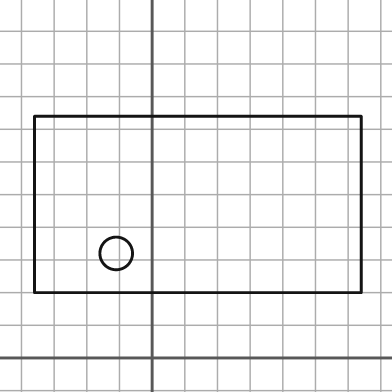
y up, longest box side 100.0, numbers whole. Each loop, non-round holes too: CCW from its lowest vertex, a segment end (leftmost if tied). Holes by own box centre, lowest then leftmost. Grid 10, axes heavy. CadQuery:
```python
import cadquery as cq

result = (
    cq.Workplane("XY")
    .moveTo(-36.0, 20.0)
    .lineTo(64.0, 20.0)
    .lineTo(64.0, 74.0)
    .lineTo(-36.0, 74.0)
    .close()
    .moveTo(-11.0, 32.0)
    .circle(5.0)
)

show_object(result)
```